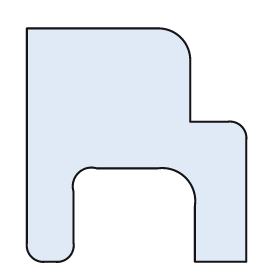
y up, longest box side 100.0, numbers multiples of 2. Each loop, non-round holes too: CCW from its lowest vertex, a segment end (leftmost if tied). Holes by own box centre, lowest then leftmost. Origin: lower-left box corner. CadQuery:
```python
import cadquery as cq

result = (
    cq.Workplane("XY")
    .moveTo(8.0, 0.0)
    .lineTo(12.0, 0.0)
    .threePointArc((18.0, 2.0), (20.0, 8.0))
    .lineTo(20.0, 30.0)
    .threePointArc((22.0, 38.0), (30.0, 40.0))
    .lineTo(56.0, 40.0)
    .threePointArc((68.0, 36.0), (72.0, 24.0))
    .lineTo(72.0, 0.0)
    .lineTo(94.0, 0.0)
    .lineTo(94.0, 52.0)
    .threePointArc((92.0, 58.0), (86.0, 60.0))
    .lineTo(70.0, 60.0)
    .lineTo(70.0, 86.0)
    .threePointArc((66.0, 96.0), (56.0, 100.0))
    .lineTo(0.0, 100.0)
    .lineTo(0.0, 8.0)
    .threePointArc((2.0, 2.0), (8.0, 0.0))
    .close()
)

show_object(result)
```